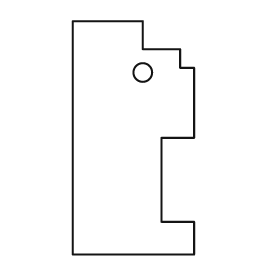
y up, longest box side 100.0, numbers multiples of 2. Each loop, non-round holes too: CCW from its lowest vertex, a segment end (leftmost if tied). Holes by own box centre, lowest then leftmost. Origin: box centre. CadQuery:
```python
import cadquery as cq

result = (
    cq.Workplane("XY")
    .moveTo(-26.0, -50.0)
    .lineTo(26.0, -50.0)
    .lineTo(26.0, -36.0)
    .lineTo(12.0, -36.0)
    .lineTo(12.0, 0.0)
    .lineTo(26.0, 0.0)
    .lineTo(26.0, 30.0)
    .lineTo(20.0, 30.0)
    .lineTo(20.0, 38.0)
    .lineTo(4.0, 38.0)
    .lineTo(4.0, 50.0)
    .lineTo(-26.0, 50.0)
    .close()
    .moveTo(4.0, 28.0)
    .circle(4.0)
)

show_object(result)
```